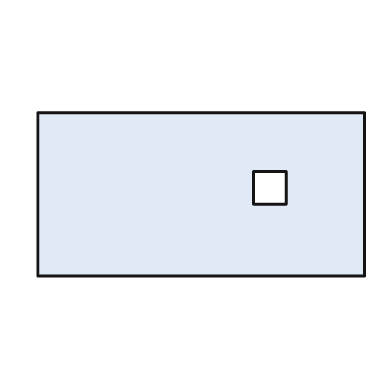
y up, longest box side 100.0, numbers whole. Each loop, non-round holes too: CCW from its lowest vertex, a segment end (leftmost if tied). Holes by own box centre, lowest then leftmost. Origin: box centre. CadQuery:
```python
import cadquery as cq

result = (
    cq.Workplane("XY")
    .moveTo(-50.0, -25.0)
    .lineTo(50.0, -25.0)
    .lineTo(50.0, 25.0)
    .lineTo(-50.0, 25.0)
    .close()
    .moveTo(16.0, -3.0)
    .lineTo(26.0, -3.0)
    .lineTo(26.0, 7.0)
    .lineTo(16.0, 7.0)
    .close()
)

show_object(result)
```